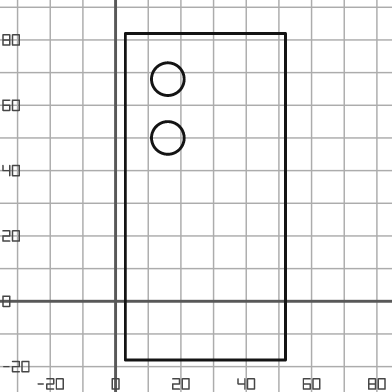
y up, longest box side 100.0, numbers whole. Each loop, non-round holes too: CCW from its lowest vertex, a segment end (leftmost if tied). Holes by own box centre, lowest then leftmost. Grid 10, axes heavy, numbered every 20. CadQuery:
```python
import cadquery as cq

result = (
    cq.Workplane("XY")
    .moveTo(3.0, -18.0)
    .lineTo(52.0, -18.0)
    .lineTo(52.0, 82.0)
    .lineTo(3.0, 82.0)
    .close()
    .moveTo(16.0, 50.0)
    .circle(5.0)
    .moveTo(16.0, 68.0)
    .circle(5.0)
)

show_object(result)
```